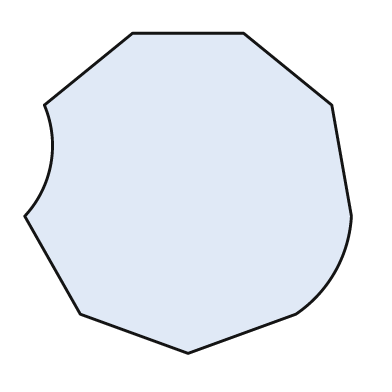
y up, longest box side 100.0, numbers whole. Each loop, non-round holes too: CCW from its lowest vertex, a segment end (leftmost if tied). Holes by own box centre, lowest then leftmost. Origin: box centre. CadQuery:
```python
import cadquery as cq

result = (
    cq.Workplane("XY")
    .moveTo(0.0, -49.0)
    .lineTo(33.0, -37.0)
    .threePointArc((45.0, -24.0), (50.0, -7.0))
    .lineTo(44.0, 27.0)
    .lineTo(17.0, 49.0)
    .lineTo(-17.0, 49.0)
    .lineTo(-44.0, 27.0)
    .threePointArc((-42.0, 9.0), (-50.0, -7.0))
    .lineTo(-33.0, -37.0)
    .close()
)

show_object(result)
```